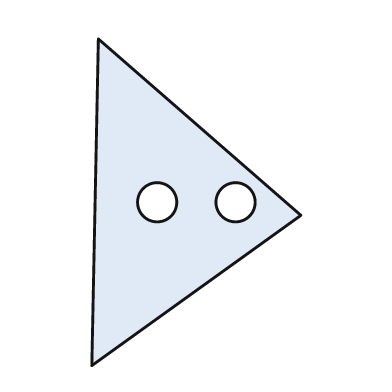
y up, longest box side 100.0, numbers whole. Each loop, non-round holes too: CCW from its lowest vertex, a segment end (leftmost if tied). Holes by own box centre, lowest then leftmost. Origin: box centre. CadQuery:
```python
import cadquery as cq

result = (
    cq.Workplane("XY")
    .moveTo(-32.0, -50.0)
    .lineTo(32.0, -4.0)
    .lineTo(-30.0, 50.0)
    .close()
    .moveTo(-12.0, 0.0)
    .circle(6.0)
    .moveTo(12.0, 0.0)
    .circle(6.0)
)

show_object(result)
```